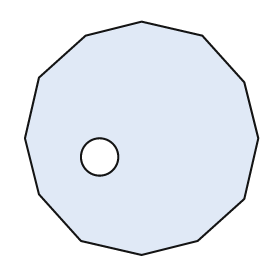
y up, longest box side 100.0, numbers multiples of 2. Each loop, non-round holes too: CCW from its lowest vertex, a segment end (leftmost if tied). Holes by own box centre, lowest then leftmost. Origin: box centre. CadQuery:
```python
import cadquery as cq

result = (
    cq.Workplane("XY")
    .moveTo(0.0, -50.0)
    .lineTo(24.0, -44.0)
    .lineTo(44.0, -26.0)
    .lineTo(50.0, 0.0)
    .lineTo(44.0, 24.0)
    .lineTo(26.0, 44.0)
    .lineTo(0.0, 50.0)
    .lineTo(-24.0, 44.0)
    .lineTo(-44.0, 26.0)
    .lineTo(-50.0, 0.0)
    .lineTo(-44.0, -24.0)
    .lineTo(-26.0, -44.0)
    .close()
    .moveTo(-18.0, -8.0)
    .circle(8.0)
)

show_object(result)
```